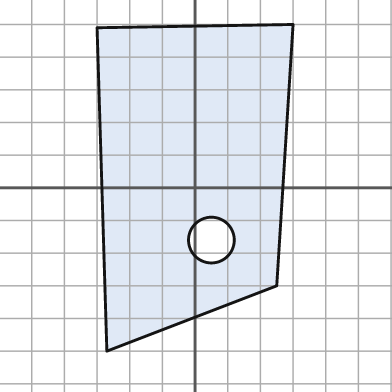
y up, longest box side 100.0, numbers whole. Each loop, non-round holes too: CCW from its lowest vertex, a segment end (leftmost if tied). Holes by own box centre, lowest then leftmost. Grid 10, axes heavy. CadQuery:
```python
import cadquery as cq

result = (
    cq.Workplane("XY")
    .moveTo(-27.0, -50.0)
    .lineTo(25.0, -30.0)
    .lineTo(30.0, 50.0)
    .lineTo(-30.0, 49.0)
    .close()
    .moveTo(5.0, -16.0)
    .circle(7.0)
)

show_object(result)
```